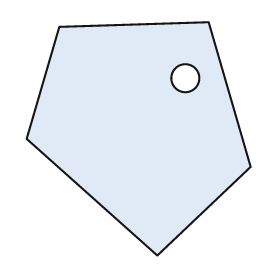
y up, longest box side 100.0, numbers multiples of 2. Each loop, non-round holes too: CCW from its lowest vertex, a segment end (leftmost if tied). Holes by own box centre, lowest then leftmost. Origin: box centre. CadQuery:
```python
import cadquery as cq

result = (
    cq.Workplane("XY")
    .moveTo(8.0, -50.0)
    .lineTo(48.0, -12.0)
    .lineTo(30.0, 50.0)
    .lineTo(-34.0, 48.0)
    .lineTo(-48.0, 0.0)
    .close()
    .moveTo(20.0, 26.0)
    .circle(6.0)
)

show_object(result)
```